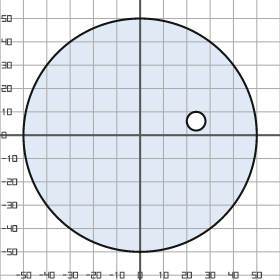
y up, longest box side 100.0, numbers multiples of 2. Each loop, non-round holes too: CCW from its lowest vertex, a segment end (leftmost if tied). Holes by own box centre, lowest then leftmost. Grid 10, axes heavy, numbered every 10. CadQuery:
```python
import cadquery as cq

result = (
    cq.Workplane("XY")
    .moveTo(0.0, 0.0)
    .circle(50.0)
    .moveTo(24.0, 6.0)
    .circle(4.0)
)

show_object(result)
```